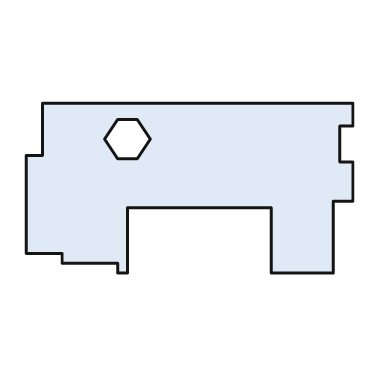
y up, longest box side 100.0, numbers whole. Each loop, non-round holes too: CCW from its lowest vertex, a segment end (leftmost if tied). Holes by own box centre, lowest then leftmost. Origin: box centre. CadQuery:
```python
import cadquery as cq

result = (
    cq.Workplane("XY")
    .moveTo(-22.0, -26.0)
    .lineTo(-19.0, -26.0)
    .lineTo(-19.0, -6.0)
    .lineTo(25.0, -6.0)
    .lineTo(25.0, -26.0)
    .lineTo(44.0, -26.0)
    .lineTo(44.0, -4.0)
    .lineTo(50.0, -4.0)
    .lineTo(50.0, 8.0)
    .lineTo(46.0, 8.0)
    .lineTo(46.0, 19.0)
    .lineTo(50.0, 19.0)
    .lineTo(50.0, 26.0)
    .lineTo(-45.0, 26.0)
    .lineTo(-45.0, 10.0)
    .lineTo(-50.0, 10.0)
    .lineTo(-50.0, -20.0)
    .lineTo(-39.0, -20.0)
    .lineTo(-39.0, -23.0)
    .lineTo(-22.0, -23.0)
    .close()
    .moveTo(-22.0, 9.0)
    .lineTo(-16.0, 9.0)
    .lineTo(-12.0, 15.0)
    .lineTo(-16.0, 21.0)
    .lineTo(-22.0, 21.0)
    .lineTo(-26.0, 15.0)
    .close()
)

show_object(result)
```